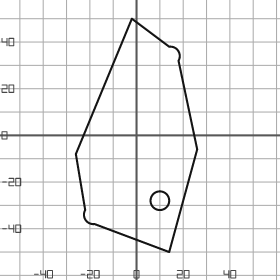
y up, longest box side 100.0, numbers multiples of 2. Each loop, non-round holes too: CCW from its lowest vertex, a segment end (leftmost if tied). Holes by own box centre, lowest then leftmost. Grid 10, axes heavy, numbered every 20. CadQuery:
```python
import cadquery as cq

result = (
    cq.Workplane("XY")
    .moveTo(14.0, -50.0)
    .lineTo(26.0, -6.0)
    .lineTo(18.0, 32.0)
    .threePointArc((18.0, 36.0), (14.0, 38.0))
    .lineTo(-2.0, 50.0)
    .lineTo(-26.0, -8.0)
    .lineTo(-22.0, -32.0)
    .threePointArc((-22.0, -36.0), (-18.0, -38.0))
    .close()
    .moveTo(10.0, -28.0)
    .circle(4.0)
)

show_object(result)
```